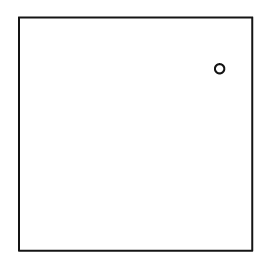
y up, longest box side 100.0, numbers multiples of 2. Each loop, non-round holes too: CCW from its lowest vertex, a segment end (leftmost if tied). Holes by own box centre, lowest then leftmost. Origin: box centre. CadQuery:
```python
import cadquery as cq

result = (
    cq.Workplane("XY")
    .moveTo(-50.0, -50.0)
    .lineTo(50.0, -50.0)
    .lineTo(50.0, 50.0)
    .lineTo(-50.0, 50.0)
    .close()
    .moveTo(36.0, 28.0)
    .circle(2.0)
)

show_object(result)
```